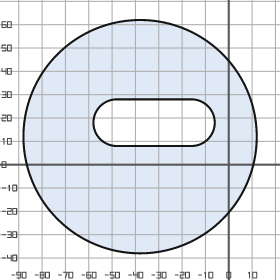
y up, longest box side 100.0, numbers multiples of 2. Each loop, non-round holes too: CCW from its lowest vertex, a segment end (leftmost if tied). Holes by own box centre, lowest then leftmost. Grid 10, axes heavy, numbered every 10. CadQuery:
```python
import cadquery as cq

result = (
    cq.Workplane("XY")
    .moveTo(-38.0, 12.0)
    .circle(50.0)
    .moveTo(-48.0, 8.0)
    .lineTo(-16.0, 8.0)
    .threePointArc((-6.0, 18.0), (-16.0, 28.0))
    .lineTo(-48.0, 28.0)
    .threePointArc((-58.0, 18.0), (-48.0, 8.0))
    .close()
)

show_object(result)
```